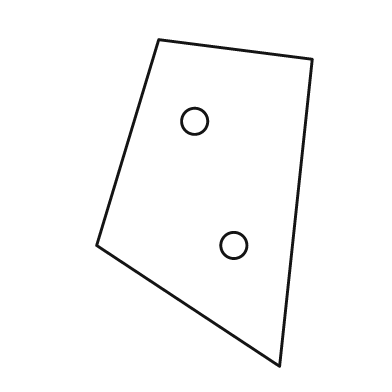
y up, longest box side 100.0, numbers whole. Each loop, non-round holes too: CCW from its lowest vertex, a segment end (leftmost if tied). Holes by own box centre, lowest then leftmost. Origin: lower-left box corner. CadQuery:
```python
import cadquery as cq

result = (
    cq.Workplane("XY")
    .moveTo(56.0, 0.0)
    .lineTo(66.0, 94.0)
    .lineTo(19.0, 100.0)
    .lineTo(0.0, 37.0)
    .close()
    .moveTo(42.0, 37.0)
    .circle(4.0)
    .moveTo(30.0, 75.0)
    .circle(4.0)
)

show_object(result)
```